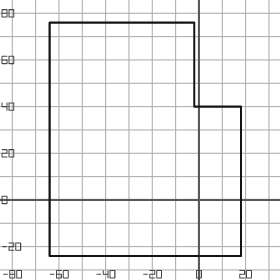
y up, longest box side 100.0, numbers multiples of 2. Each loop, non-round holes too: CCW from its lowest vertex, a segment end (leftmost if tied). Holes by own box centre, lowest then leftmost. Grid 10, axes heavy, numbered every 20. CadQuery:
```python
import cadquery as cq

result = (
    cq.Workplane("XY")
    .moveTo(-64.0, -24.0)
    .lineTo(18.0, -24.0)
    .lineTo(18.0, 40.0)
    .lineTo(-2.0, 40.0)
    .lineTo(-2.0, 76.0)
    .lineTo(-64.0, 76.0)
    .close()
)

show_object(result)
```